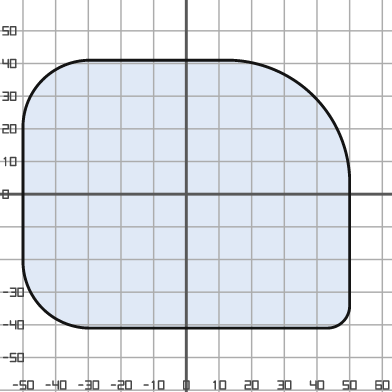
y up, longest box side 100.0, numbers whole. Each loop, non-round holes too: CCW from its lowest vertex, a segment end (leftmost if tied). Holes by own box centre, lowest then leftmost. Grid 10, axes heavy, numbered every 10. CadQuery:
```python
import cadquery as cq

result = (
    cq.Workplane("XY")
    .moveTo(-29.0, -41.0)
    .lineTo(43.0, -41.0)
    .threePointArc((48.0, -39.0), (50.0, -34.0))
    .lineTo(50.0, 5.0)
    .threePointArc((39.0, 30.0), (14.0, 41.0))
    .lineTo(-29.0, 41.0)
    .threePointArc((-44.0, 35.0), (-50.0, 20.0))
    .lineTo(-50.0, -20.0)
    .threePointArc((-44.0, -35.0), (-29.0, -41.0))
    .close()
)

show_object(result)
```